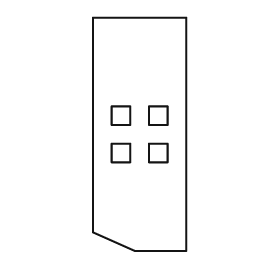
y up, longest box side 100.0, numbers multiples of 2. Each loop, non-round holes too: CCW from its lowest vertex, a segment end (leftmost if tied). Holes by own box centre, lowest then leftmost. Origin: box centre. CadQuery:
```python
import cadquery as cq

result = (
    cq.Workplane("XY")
    .moveTo(-2.0, -50.0)
    .lineTo(20.0, -50.0)
    .lineTo(20.0, 50.0)
    .lineTo(-20.0, 50.0)
    .lineTo(-20.0, -42.0)
    .close()
    .moveTo(-12.0, -12.0)
    .lineTo(-4.0, -12.0)
    .lineTo(-4.0, -4.0)
    .lineTo(-12.0, -4.0)
    .close()
    .moveTo(4.0, -12.0)
    .lineTo(12.0, -12.0)
    .lineTo(12.0, -4.0)
    .lineTo(4.0, -4.0)
    .close()
    .moveTo(-12.0, 4.0)
    .lineTo(-4.0, 4.0)
    .lineTo(-4.0, 12.0)
    .lineTo(-12.0, 12.0)
    .close()
    .moveTo(4.0, 4.0)
    .lineTo(12.0, 4.0)
    .lineTo(12.0, 12.0)
    .lineTo(4.0, 12.0)
    .close()
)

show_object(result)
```